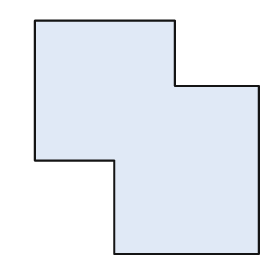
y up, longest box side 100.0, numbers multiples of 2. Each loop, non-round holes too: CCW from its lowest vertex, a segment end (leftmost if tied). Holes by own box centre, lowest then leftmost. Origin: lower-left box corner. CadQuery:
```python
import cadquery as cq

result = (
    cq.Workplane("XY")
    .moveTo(34.0, 0.0)
    .lineTo(96.0, 0.0)
    .lineTo(96.0, 72.0)
    .lineTo(60.0, 72.0)
    .lineTo(60.0, 100.0)
    .lineTo(0.0, 100.0)
    .lineTo(0.0, 40.0)
    .lineTo(34.0, 40.0)
    .close()
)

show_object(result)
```